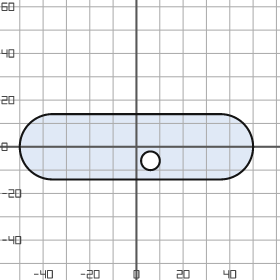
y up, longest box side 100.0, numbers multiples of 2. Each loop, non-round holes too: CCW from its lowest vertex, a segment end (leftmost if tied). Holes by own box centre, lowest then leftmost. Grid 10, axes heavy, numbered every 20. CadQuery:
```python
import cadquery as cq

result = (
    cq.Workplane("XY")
    .moveTo(-36.0, -14.0)
    .lineTo(36.0, -14.0)
    .threePointArc((50.0, 0.0), (36.0, 14.0))
    .lineTo(-36.0, 14.0)
    .threePointArc((-50.0, 0.0), (-36.0, -14.0))
    .close()
    .moveTo(6.0, -6.0)
    .circle(4.0)
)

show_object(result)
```